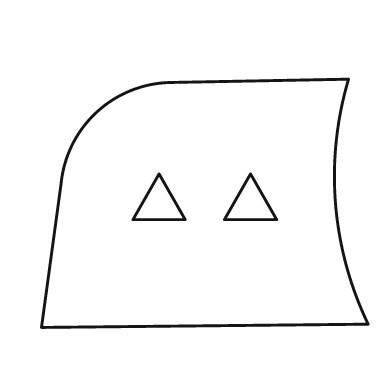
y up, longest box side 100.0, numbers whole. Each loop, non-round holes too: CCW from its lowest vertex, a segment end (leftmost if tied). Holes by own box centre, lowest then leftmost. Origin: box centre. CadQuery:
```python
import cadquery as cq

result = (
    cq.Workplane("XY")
    .moveTo(-50.0, -38.0)
    .lineTo(50.0, -37.0)
    .threePointArc((40.0, 0.0), (44.0, 38.0))
    .lineTo(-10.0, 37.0)
    .threePointArc((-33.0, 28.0), (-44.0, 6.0))
    .close()
    .moveTo(-22.0, -5.0)
    .lineTo(-6.0, -5.0)
    .lineTo(-14.0, 9.0)
    .close()
    .moveTo(6.0, -5.0)
    .lineTo(22.0, -5.0)
    .lineTo(14.0, 9.0)
    .close()
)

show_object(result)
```